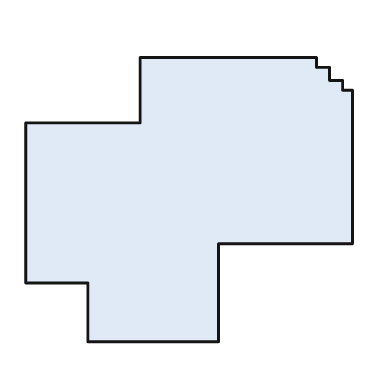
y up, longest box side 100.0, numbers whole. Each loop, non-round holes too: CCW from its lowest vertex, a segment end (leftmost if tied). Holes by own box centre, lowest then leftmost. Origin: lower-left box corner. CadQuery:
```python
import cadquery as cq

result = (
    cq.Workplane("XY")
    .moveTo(19.0, 0.0)
    .lineTo(59.0, 0.0)
    .lineTo(59.0, 30.0)
    .lineTo(100.0, 30.0)
    .lineTo(100.0, 77.0)
    .lineTo(97.0, 77.0)
    .lineTo(97.0, 80.0)
    .lineTo(93.0, 80.0)
    .lineTo(93.0, 84.0)
    .lineTo(89.0, 84.0)
    .lineTo(89.0, 87.0)
    .lineTo(35.0, 87.0)
    .lineTo(35.0, 67.0)
    .lineTo(0.0, 67.0)
    .lineTo(0.0, 18.0)
    .lineTo(19.0, 18.0)
    .close()
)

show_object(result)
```